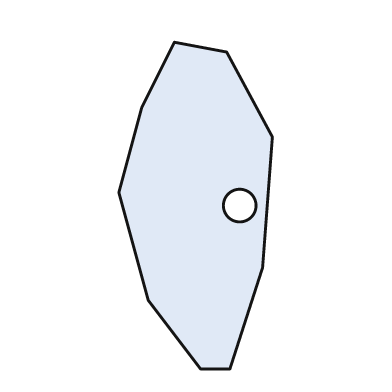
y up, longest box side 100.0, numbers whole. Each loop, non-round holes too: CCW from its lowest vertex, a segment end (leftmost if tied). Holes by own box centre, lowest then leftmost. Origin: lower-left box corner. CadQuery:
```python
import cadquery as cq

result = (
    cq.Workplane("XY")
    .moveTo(25.0, 0.0)
    .lineTo(34.0, 0.0)
    .lineTo(44.0, 31.0)
    .lineTo(47.0, 71.0)
    .lineTo(33.0, 97.0)
    .lineTo(17.0, 100.0)
    .lineTo(7.0, 80.0)
    .lineTo(0.0, 54.0)
    .lineTo(9.0, 21.0)
    .close()
    .moveTo(37.0, 50.0)
    .circle(5.0)
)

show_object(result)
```